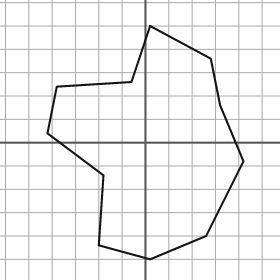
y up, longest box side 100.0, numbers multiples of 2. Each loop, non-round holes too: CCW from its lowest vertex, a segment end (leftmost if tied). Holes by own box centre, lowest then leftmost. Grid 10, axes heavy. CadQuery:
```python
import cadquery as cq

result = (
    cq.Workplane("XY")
    .moveTo(2.0, -50.0)
    .lineTo(26.0, -40.0)
    .lineTo(42.0, -8.0)
    .lineTo(32.0, 16.0)
    .lineTo(28.0, 36.0)
    .lineTo(2.0, 50.0)
    .lineTo(-6.0, 26.0)
    .lineTo(-38.0, 24.0)
    .lineTo(-42.0, 4.0)
    .lineTo(-18.0, -14.0)
    .lineTo(-20.0, -44.0)
    .close()
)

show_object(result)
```